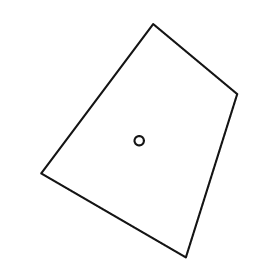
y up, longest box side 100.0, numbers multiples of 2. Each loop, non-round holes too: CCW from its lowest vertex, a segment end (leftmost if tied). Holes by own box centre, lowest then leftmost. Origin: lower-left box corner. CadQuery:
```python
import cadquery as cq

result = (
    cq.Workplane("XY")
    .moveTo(62.0, 0.0)
    .lineTo(84.0, 70.0)
    .lineTo(48.0, 100.0)
    .lineTo(0.0, 36.0)
    .close()
    .moveTo(42.0, 50.0)
    .circle(2.0)
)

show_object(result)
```